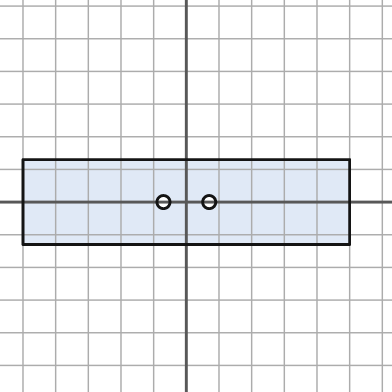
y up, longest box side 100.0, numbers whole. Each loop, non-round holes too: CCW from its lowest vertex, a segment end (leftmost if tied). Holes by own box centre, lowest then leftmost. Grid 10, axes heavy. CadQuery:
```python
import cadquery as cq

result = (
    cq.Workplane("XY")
    .moveTo(-50.0, -13.0)
    .lineTo(50.0, -13.0)
    .lineTo(50.0, 13.0)
    .lineTo(-50.0, 13.0)
    .close()
    .moveTo(-7.0, 0.0)
    .circle(2.0)
    .moveTo(7.0, 0.0)
    .circle(2.0)
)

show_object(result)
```